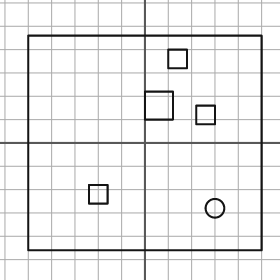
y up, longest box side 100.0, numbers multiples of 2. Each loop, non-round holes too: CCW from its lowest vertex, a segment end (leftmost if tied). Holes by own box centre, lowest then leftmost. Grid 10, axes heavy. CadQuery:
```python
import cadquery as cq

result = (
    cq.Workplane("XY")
    .moveTo(-50.0, -46.0)
    .lineTo(50.0, -46.0)
    .lineTo(50.0, 46.0)
    .lineTo(-50.0, 46.0)
    .close()
    .moveTo(30.0, -28.0)
    .circle(4.0)
    .moveTo(-24.0, -26.0)
    .lineTo(-16.0, -26.0)
    .lineTo(-16.0, -18.0)
    .lineTo(-24.0, -18.0)
    .close()
    .moveTo(22.0, 8.0)
    .lineTo(30.0, 8.0)
    .lineTo(30.0, 16.0)
    .lineTo(22.0, 16.0)
    .close()
    .moveTo(0.0, 10.0)
    .lineTo(12.0, 10.0)
    .lineTo(12.0, 22.0)
    .lineTo(0.0, 22.0)
    .close()
    .moveTo(10.0, 32.0)
    .lineTo(18.0, 32.0)
    .lineTo(18.0, 40.0)
    .lineTo(10.0, 40.0)
    .close()
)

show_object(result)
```